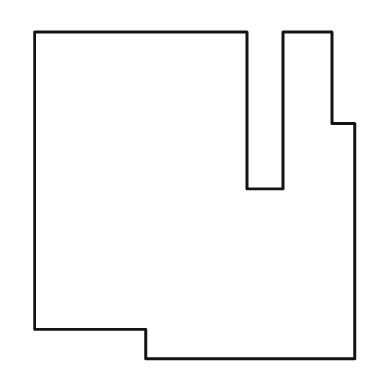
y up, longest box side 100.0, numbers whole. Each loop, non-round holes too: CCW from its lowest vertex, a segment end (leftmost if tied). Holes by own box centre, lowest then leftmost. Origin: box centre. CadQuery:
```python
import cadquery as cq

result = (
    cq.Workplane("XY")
    .moveTo(-15.0, -50.0)
    .lineTo(49.0, -50.0)
    .lineTo(49.0, 22.0)
    .lineTo(42.0, 22.0)
    .lineTo(42.0, 50.0)
    .lineTo(27.0, 50.0)
    .lineTo(27.0, 2.0)
    .lineTo(16.0, 2.0)
    .lineTo(16.0, 50.0)
    .lineTo(-49.0, 50.0)
    .lineTo(-49.0, -41.0)
    .lineTo(-15.0, -41.0)
    .close()
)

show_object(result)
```